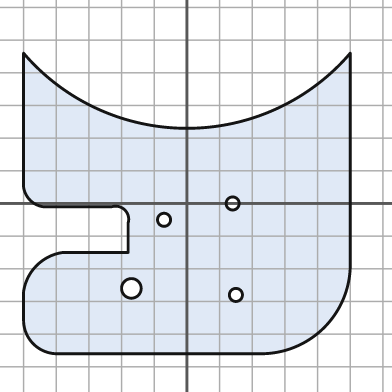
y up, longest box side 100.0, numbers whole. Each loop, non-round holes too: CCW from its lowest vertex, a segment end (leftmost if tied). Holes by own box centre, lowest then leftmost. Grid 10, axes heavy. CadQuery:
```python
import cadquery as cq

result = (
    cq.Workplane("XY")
    .moveTo(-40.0, -46.0)
    .lineTo(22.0, -46.0)
    .threePointArc((42.0, -38.0), (50.0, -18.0))
    .lineTo(50.0, 46.0)
    .threePointArc((0.0, 23.0), (-50.0, 46.0))
    .lineTo(-50.0, 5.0)
    .threePointArc((-48.0, 1.0), (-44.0, -1.0))
    .lineTo(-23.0, -1.0)
    .threePointArc((-19.0, -2.0), (-18.0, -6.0))
    .lineTo(-18.0, -15.0)
    .lineTo(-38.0, -15.0)
    .threePointArc((-46.0, -19.0), (-50.0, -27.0))
    .lineTo(-50.0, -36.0)
    .threePointArc((-47.0, -43.0), (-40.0, -46.0))
    .close()
    .moveTo(15.0, -28.0)
    .circle(2.0)
    .moveTo(-17.0, -26.0)
    .circle(3.0)
    .moveTo(-7.0, -5.0)
    .circle(2.0)
    .moveTo(14.0, 0.0)
    .circle(2.0)
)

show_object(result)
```